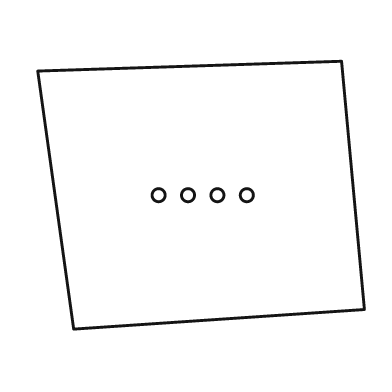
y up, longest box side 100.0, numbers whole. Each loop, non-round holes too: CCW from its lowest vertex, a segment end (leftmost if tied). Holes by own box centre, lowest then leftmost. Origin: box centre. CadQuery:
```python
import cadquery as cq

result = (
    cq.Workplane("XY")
    .moveTo(-39.0, -41.0)
    .lineTo(50.0, -35.0)
    .lineTo(43.0, 41.0)
    .lineTo(-50.0, 38.0)
    .close()
    .moveTo(-13.0, 0.0)
    .circle(2.0)
    .moveTo(-4.0, 0.0)
    .circle(2.0)
    .moveTo(5.0, 0.0)
    .circle(2.0)
    .moveTo(14.0, 0.0)
    .circle(2.0)
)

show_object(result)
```